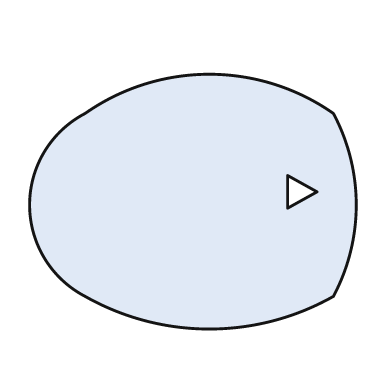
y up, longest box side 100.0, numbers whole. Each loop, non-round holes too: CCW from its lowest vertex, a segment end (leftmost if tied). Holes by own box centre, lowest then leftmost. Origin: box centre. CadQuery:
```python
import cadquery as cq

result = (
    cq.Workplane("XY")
    .moveTo(-33.0, -29.0)
    .threePointArc((5.0, -39.0), (43.0, -29.0))
    .threePointArc((50.0, -1.0), (43.0, 27.0))
    .threePointArc((5.0, 39.0), (-33.0, 27.0))
    .threePointArc((-50.0, -1.0), (-33.0, -29.0))
    .close()
    .moveTo(29.0, -2.0)
    .lineTo(38.0, 3.0)
    .lineTo(29.0, 8.0)
    .close()
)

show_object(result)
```